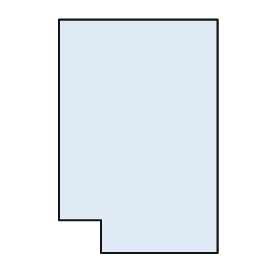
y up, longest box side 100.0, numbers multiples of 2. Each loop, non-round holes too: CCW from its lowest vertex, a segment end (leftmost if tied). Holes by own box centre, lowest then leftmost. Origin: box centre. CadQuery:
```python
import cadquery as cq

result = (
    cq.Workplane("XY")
    .moveTo(-16.0, -50.0)
    .lineTo(34.0, -50.0)
    .lineTo(34.0, 50.0)
    .lineTo(-34.0, 50.0)
    .lineTo(-34.0, -36.0)
    .lineTo(-16.0, -36.0)
    .close()
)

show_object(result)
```